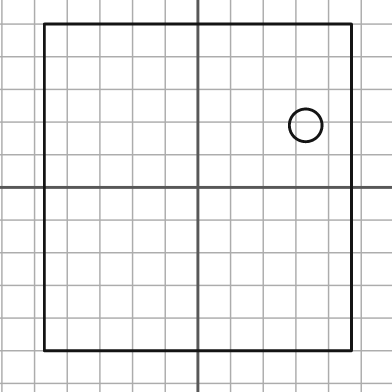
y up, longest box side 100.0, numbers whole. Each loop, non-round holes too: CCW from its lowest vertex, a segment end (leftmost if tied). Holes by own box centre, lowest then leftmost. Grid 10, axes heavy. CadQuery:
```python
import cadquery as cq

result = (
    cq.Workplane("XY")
    .moveTo(-47.0, -50.0)
    .lineTo(47.0, -50.0)
    .lineTo(47.0, 50.0)
    .lineTo(-47.0, 50.0)
    .close()
    .moveTo(33.0, 19.0)
    .circle(5.0)
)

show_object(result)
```